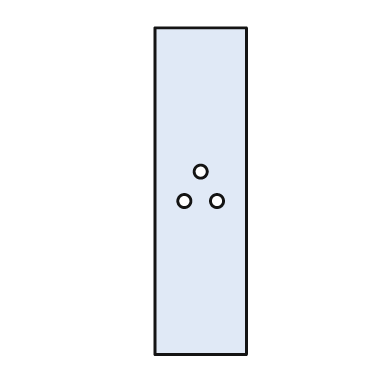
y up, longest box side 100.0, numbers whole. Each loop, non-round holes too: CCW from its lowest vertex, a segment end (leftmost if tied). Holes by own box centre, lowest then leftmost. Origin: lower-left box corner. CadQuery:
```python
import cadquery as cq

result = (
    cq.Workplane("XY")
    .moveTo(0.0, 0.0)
    .lineTo(28.0, 0.0)
    .lineTo(28.0, 100.0)
    .lineTo(0.0, 100.0)
    .close()
    .moveTo(9.0, 47.0)
    .circle(2.0)
    .moveTo(19.0, 47.0)
    .circle(2.0)
    .moveTo(14.0, 56.0)
    .circle(2.0)
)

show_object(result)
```